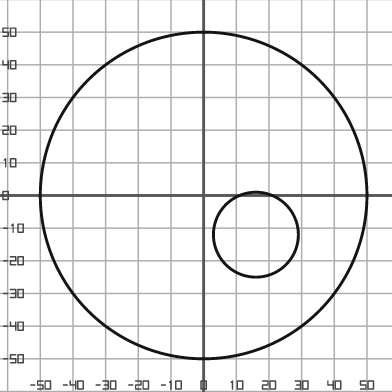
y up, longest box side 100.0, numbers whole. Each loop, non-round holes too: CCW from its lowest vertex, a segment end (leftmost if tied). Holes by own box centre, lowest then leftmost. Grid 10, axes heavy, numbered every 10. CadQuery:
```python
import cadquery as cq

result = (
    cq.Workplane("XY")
    .moveTo(0.0, 0.0)
    .circle(50.0)
    .moveTo(16.0, -12.0)
    .circle(13.0)
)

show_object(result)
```